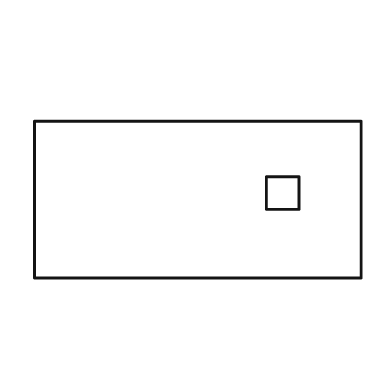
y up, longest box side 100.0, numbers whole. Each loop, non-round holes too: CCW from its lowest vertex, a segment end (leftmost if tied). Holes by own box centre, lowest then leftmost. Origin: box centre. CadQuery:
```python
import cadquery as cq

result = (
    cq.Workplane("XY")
    .moveTo(-50.0, -24.0)
    .lineTo(50.0, -24.0)
    .lineTo(50.0, 24.0)
    .lineTo(-50.0, 24.0)
    .close()
    .moveTo(21.0, -3.0)
    .lineTo(31.0, -3.0)
    .lineTo(31.0, 7.0)
    .lineTo(21.0, 7.0)
    .close()
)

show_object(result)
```